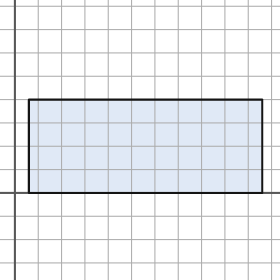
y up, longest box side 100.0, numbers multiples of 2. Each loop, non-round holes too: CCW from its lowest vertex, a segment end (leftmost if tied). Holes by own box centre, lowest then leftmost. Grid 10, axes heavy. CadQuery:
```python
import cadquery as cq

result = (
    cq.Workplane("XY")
    .moveTo(6.0, 0.0)
    .lineTo(106.0, 0.0)
    .lineTo(106.0, 40.0)
    .lineTo(6.0, 40.0)
    .close()
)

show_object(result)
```